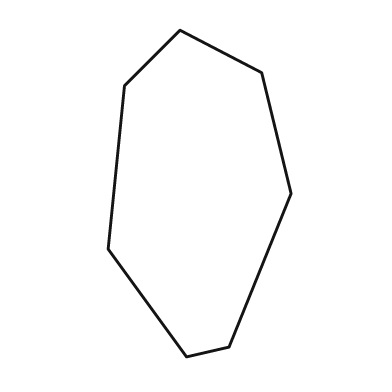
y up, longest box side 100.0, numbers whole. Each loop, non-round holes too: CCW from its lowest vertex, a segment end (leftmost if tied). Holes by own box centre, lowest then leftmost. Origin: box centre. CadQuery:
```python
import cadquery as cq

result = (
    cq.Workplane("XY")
    .moveTo(-4.0, -50.0)
    .lineTo(9.0, -47.0)
    .lineTo(28.0, 0.0)
    .lineTo(19.0, 37.0)
    .lineTo(-6.0, 50.0)
    .lineTo(-23.0, 33.0)
    .lineTo(-28.0, -17.0)
    .close()
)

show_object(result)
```